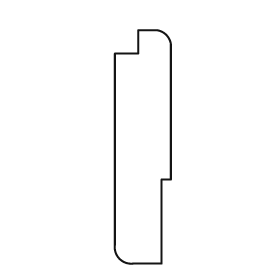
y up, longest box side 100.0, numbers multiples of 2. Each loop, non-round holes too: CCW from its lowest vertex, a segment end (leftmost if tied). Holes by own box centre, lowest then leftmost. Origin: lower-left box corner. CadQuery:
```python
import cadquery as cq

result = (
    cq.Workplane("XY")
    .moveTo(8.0, 0.0)
    .lineTo(20.0, 0.0)
    .lineTo(20.0, 36.0)
    .lineTo(24.0, 36.0)
    .lineTo(24.0, 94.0)
    .threePointArc((22.0, 98.0), (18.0, 100.0))
    .lineTo(10.0, 100.0)
    .lineTo(10.0, 90.0)
    .lineTo(0.0, 90.0)
    .lineTo(0.0, 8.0)
    .threePointArc((2.0, 2.0), (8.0, 0.0))
    .close()
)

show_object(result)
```